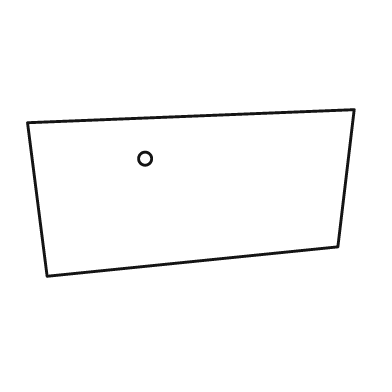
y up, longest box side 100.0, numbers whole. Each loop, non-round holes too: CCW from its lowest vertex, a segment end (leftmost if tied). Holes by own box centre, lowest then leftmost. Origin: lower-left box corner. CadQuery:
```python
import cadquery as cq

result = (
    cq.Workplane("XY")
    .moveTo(6.0, 0.0)
    .lineTo(95.0, 9.0)
    .lineTo(100.0, 51.0)
    .lineTo(0.0, 47.0)
    .close()
    .moveTo(36.0, 36.0)
    .circle(2.0)
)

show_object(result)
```